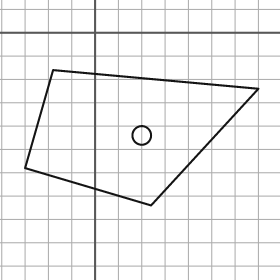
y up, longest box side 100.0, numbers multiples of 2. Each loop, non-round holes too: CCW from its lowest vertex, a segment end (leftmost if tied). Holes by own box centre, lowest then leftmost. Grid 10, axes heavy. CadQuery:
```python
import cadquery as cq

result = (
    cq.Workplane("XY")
    .moveTo(24.0, -74.0)
    .lineTo(70.0, -24.0)
    .lineTo(-18.0, -16.0)
    .lineTo(-30.0, -58.0)
    .close()
    .moveTo(20.0, -44.0)
    .circle(4.0)
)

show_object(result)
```